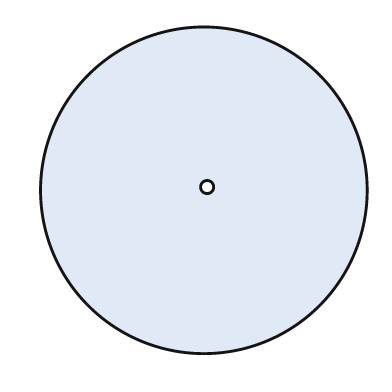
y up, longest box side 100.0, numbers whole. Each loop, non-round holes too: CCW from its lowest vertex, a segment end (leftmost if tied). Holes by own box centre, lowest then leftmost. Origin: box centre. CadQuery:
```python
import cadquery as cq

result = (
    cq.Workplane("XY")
    .moveTo(0.0, 0.0)
    .circle(50.0)
    .moveTo(1.0, 1.0)
    .circle(2.0)
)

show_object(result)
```